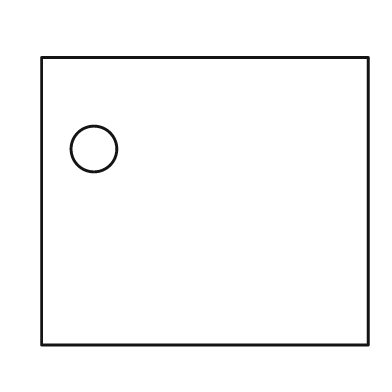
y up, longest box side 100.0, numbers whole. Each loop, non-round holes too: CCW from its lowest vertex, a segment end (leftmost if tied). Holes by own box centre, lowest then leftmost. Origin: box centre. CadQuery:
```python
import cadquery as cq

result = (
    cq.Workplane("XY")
    .moveTo(-50.0, -44.0)
    .lineTo(50.0, -44.0)
    .lineTo(50.0, 44.0)
    .lineTo(-50.0, 44.0)
    .close()
    .moveTo(-34.0, 16.0)
    .circle(7.0)
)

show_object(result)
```